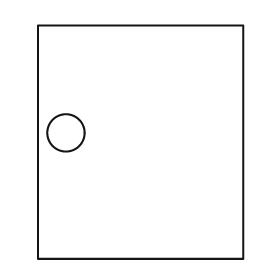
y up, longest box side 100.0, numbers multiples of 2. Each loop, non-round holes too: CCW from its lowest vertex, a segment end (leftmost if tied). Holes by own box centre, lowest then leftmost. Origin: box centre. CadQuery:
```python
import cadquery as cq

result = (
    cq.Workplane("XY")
    .moveTo(-44.0, -50.0)
    .lineTo(44.0, -50.0)
    .lineTo(44.0, 50.0)
    .lineTo(-44.0, 50.0)
    .close()
    .moveTo(-32.0, 4.0)
    .circle(8.0)
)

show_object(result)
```